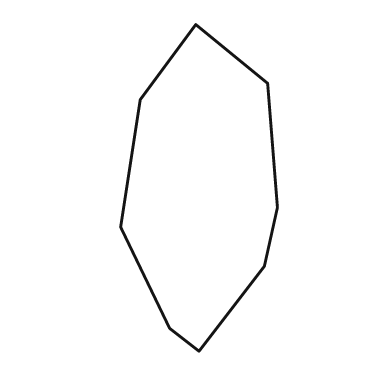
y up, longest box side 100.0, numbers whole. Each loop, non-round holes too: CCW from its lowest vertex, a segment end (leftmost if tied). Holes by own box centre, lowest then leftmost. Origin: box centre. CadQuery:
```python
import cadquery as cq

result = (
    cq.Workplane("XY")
    .moveTo(0.0, -50.0)
    .lineTo(20.0, -24.0)
    .lineTo(24.0, -6.0)
    .lineTo(21.0, 32.0)
    .lineTo(-1.0, 50.0)
    .lineTo(-18.0, 27.0)
    .lineTo(-24.0, -12.0)
    .lineTo(-9.0, -43.0)
    .close()
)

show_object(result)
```